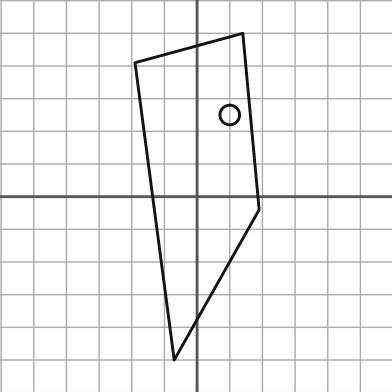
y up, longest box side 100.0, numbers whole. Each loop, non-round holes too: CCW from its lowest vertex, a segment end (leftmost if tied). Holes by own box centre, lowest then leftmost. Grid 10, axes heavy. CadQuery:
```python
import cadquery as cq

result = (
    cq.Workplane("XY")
    .moveTo(-7.0, -50.0)
    .lineTo(19.0, -4.0)
    .lineTo(14.0, 50.0)
    .lineTo(-19.0, 41.0)
    .close()
    .moveTo(10.0, 25.0)
    .circle(3.0)
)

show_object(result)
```